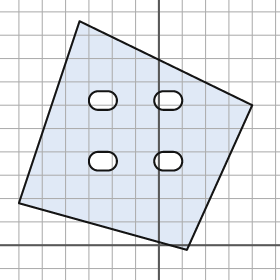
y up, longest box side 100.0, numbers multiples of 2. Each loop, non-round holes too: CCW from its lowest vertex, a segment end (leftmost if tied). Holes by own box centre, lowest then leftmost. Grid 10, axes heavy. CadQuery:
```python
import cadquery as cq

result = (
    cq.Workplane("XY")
    .moveTo(12.0, -2.0)
    .lineTo(40.0, 60.0)
    .lineTo(-34.0, 96.0)
    .lineTo(-60.0, 18.0)
    .close()
    .moveTo(-26.0, 32.0)
    .lineTo(-22.0, 32.0)
    .threePointArc((-18.0, 36.0), (-22.0, 40.0))
    .lineTo(-26.0, 40.0)
    .threePointArc((-30.0, 36.0), (-26.0, 32.0))
    .close()
    .moveTo(2.0, 32.0)
    .lineTo(6.0, 32.0)
    .threePointArc((10.0, 36.0), (6.0, 40.0))
    .lineTo(2.0, 40.0)
    .threePointArc((-2.0, 36.0), (2.0, 32.0))
    .close()
    .moveTo(-26.0, 58.0)
    .lineTo(-22.0, 58.0)
    .threePointArc((-18.0, 62.0), (-22.0, 66.0))
    .lineTo(-26.0, 66.0)
    .threePointArc((-30.0, 62.0), (-26.0, 58.0))
    .close()
    .moveTo(2.0, 58.0)
    .lineTo(6.0, 58.0)
    .threePointArc((10.0, 62.0), (6.0, 66.0))
    .lineTo(2.0, 66.0)
    .threePointArc((-2.0, 62.0), (2.0, 58.0))
    .close()
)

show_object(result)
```